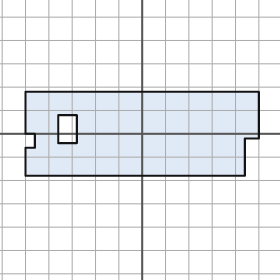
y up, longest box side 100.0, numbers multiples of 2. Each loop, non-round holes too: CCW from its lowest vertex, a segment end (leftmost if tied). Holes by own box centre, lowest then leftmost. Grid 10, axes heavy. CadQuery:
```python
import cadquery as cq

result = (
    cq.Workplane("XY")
    .moveTo(-50.0, -18.0)
    .lineTo(44.0, -18.0)
    .lineTo(44.0, -2.0)
    .lineTo(50.0, -2.0)
    .lineTo(50.0, 18.0)
    .lineTo(-50.0, 18.0)
    .lineTo(-50.0, 0.0)
    .lineTo(-46.0, 0.0)
    .lineTo(-46.0, -6.0)
    .lineTo(-50.0, -6.0)
    .close()
    .moveTo(-36.0, -4.0)
    .lineTo(-28.0, -4.0)
    .lineTo(-28.0, 8.0)
    .lineTo(-36.0, 8.0)
    .close()
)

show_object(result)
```